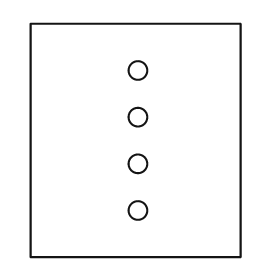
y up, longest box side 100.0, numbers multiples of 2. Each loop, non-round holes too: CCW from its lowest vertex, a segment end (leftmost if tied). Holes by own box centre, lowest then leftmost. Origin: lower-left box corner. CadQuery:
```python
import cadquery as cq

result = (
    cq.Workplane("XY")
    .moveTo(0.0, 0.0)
    .lineTo(90.0, 0.0)
    .lineTo(90.0, 100.0)
    .lineTo(0.0, 100.0)
    .close()
    .moveTo(46.0, 20.0)
    .circle(4.0)
    .moveTo(46.0, 40.0)
    .circle(4.0)
    .moveTo(46.0, 60.0)
    .circle(4.0)
    .moveTo(46.0, 80.0)
    .circle(4.0)
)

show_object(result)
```